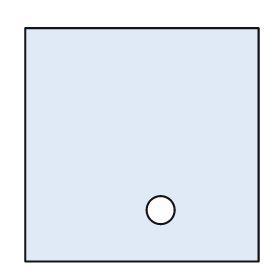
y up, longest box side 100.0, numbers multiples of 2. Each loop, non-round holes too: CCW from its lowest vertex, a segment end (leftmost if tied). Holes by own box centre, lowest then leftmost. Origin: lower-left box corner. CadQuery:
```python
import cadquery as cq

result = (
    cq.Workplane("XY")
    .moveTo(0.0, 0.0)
    .lineTo(100.0, 0.0)
    .lineTo(100.0, 100.0)
    .lineTo(0.0, 100.0)
    .close()
    .moveTo(58.0, 22.0)
    .circle(6.0)
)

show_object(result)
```